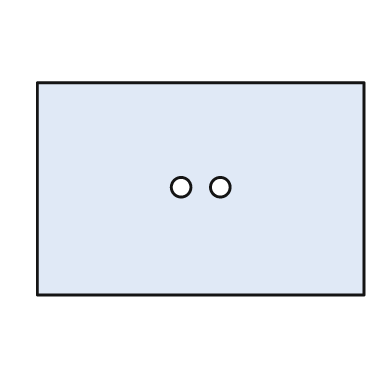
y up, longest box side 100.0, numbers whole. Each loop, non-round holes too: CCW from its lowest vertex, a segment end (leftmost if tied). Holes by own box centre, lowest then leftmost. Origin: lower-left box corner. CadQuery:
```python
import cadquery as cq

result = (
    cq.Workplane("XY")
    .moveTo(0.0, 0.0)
    .lineTo(100.0, 0.0)
    .lineTo(100.0, 65.0)
    .lineTo(0.0, 65.0)
    .close()
    .moveTo(44.0, 33.0)
    .circle(3.0)
    .moveTo(56.0, 33.0)
    .circle(3.0)
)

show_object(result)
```